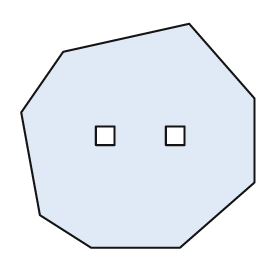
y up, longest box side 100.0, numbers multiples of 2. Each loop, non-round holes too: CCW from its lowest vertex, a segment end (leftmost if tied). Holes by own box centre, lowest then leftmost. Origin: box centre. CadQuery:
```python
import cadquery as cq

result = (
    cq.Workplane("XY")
    .moveTo(-20.0, -48.0)
    .lineTo(18.0, -48.0)
    .lineTo(50.0, -20.0)
    .lineTo(50.0, 16.0)
    .lineTo(22.0, 48.0)
    .lineTo(-32.0, 36.0)
    .lineTo(-50.0, 10.0)
    .lineTo(-42.0, -34.0)
    .close()
    .moveTo(-18.0, -4.0)
    .lineTo(-10.0, -4.0)
    .lineTo(-10.0, 4.0)
    .lineTo(-18.0, 4.0)
    .close()
    .moveTo(12.0, -4.0)
    .lineTo(20.0, -4.0)
    .lineTo(20.0, 4.0)
    .lineTo(12.0, 4.0)
    .close()
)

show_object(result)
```